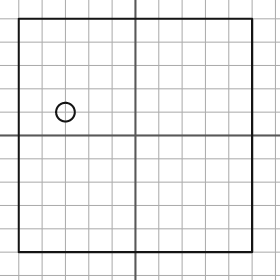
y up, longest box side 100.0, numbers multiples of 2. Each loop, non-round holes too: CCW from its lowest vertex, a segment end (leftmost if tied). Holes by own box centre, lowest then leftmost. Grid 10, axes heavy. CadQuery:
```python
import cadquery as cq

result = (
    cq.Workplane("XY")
    .moveTo(-50.0, -50.0)
    .lineTo(50.0, -50.0)
    .lineTo(50.0, 50.0)
    .lineTo(-50.0, 50.0)
    .close()
    .moveTo(-30.0, 10.0)
    .circle(4.0)
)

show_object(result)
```